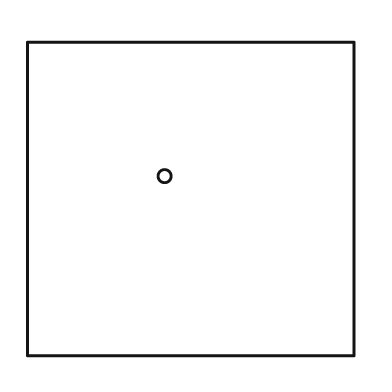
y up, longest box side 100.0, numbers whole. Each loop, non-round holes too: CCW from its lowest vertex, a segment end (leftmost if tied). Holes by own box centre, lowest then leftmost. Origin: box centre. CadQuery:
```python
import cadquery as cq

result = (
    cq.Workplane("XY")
    .moveTo(-50.0, -48.0)
    .lineTo(50.0, -48.0)
    .lineTo(50.0, 48.0)
    .lineTo(-50.0, 48.0)
    .close()
    .moveTo(-8.0, 7.0)
    .circle(2.0)
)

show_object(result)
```